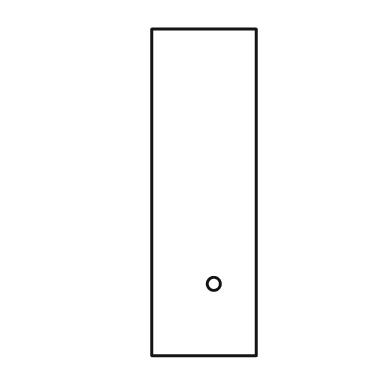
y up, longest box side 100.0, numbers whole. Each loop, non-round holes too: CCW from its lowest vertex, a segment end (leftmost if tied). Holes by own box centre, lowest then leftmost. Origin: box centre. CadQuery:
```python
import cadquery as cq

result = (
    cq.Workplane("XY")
    .moveTo(-16.0, -50.0)
    .lineTo(16.0, -50.0)
    .lineTo(16.0, 50.0)
    .lineTo(-16.0, 50.0)
    .close()
    .moveTo(3.0, -28.0)
    .circle(2.0)
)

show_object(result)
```